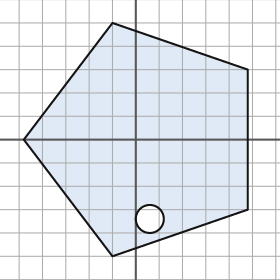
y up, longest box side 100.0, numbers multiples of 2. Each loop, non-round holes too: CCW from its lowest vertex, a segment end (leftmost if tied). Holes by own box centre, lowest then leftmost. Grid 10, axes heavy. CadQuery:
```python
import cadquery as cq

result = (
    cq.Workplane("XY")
    .moveTo(-10.0, -50.0)
    .lineTo(48.0, -30.0)
    .lineTo(48.0, 30.0)
    .lineTo(-10.0, 50.0)
    .lineTo(-48.0, 0.0)
    .close()
    .moveTo(6.0, -34.0)
    .circle(6.0)
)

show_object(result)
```